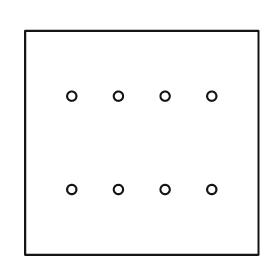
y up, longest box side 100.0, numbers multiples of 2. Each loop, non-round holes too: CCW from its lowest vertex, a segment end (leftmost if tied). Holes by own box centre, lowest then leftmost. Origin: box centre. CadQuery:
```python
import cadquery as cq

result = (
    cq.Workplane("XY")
    .moveTo(-50.0, -48.0)
    .lineTo(50.0, -48.0)
    .lineTo(50.0, 48.0)
    .lineTo(-50.0, 48.0)
    .close()
    .moveTo(-30.0, -20.0)
    .circle(2.0)
    .moveTo(-10.0, -20.0)
    .circle(2.0)
    .moveTo(10.0, -20.0)
    .circle(2.0)
    .moveTo(30.0, -20.0)
    .circle(2.0)
    .moveTo(-30.0, 20.0)
    .circle(2.0)
    .moveTo(-10.0, 20.0)
    .circle(2.0)
    .moveTo(10.0, 20.0)
    .circle(2.0)
    .moveTo(30.0, 20.0)
    .circle(2.0)
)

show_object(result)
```